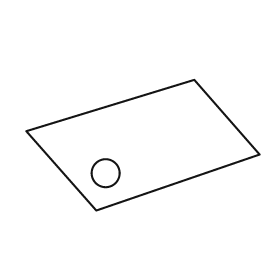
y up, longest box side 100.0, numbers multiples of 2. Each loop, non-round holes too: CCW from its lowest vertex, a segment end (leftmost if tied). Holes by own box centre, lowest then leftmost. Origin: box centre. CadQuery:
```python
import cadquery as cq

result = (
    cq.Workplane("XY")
    .moveTo(-20.0, -28.0)
    .lineTo(50.0, -4.0)
    .lineTo(22.0, 28.0)
    .lineTo(-50.0, 6.0)
    .close()
    .moveTo(-16.0, -12.0)
    .circle(6.0)
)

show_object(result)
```